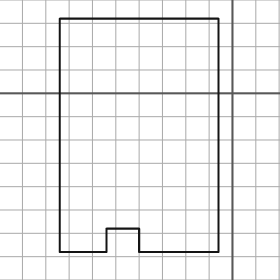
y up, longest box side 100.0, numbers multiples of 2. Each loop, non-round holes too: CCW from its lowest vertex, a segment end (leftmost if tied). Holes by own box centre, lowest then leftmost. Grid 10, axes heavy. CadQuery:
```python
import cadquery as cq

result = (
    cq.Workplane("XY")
    .moveTo(-74.0, -68.0)
    .lineTo(-54.0, -68.0)
    .lineTo(-54.0, -58.0)
    .lineTo(-40.0, -58.0)
    .lineTo(-40.0, -68.0)
    .lineTo(-6.0, -68.0)
    .lineTo(-6.0, 32.0)
    .lineTo(-74.0, 32.0)
    .close()
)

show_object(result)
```